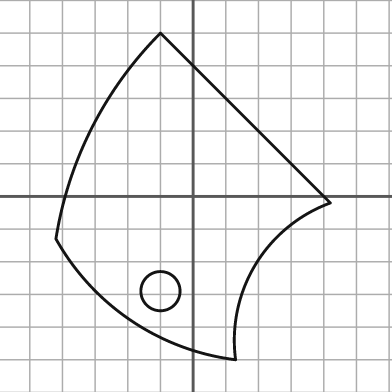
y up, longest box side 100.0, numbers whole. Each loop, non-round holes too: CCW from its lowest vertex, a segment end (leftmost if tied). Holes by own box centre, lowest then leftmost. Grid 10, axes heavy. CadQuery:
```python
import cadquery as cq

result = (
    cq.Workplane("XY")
    .moveTo(13.0, -50.0)
    .threePointArc((19.0, -21.0), (42.0, -2.0))
    .lineTo(-10.0, 50.0)
    .threePointArc((-31.0, 21.0), (-42.0, -13.0))
    .threePointArc((-19.0, -38.0), (13.0, -50.0))
    .close()
    .moveTo(-10.0, -29.0)
    .circle(6.0)
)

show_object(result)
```